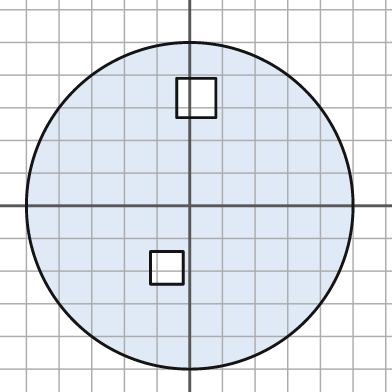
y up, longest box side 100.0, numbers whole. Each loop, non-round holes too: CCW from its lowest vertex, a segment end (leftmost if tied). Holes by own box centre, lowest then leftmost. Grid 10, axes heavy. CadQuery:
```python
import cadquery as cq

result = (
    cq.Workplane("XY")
    .moveTo(0.0, 0.0)
    .circle(50.0)
    .moveTo(-12.0, -24.0)
    .lineTo(-2.0, -24.0)
    .lineTo(-2.0, -14.0)
    .lineTo(-12.0, -14.0)
    .close()
    .moveTo(-4.0, 27.0)
    .lineTo(8.0, 27.0)
    .lineTo(8.0, 39.0)
    .lineTo(-4.0, 39.0)
    .close()
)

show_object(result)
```